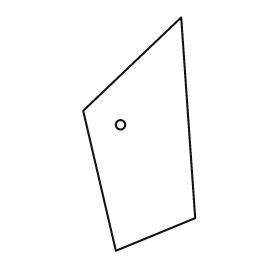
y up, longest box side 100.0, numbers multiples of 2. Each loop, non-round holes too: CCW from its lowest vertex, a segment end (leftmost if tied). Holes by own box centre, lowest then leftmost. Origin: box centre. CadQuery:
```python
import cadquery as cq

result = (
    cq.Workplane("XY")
    .moveTo(-10.0, -50.0)
    .lineTo(24.0, -36.0)
    .lineTo(18.0, 50.0)
    .lineTo(-24.0, 10.0)
    .close()
    .moveTo(-8.0, 4.0)
    .circle(2.0)
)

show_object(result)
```